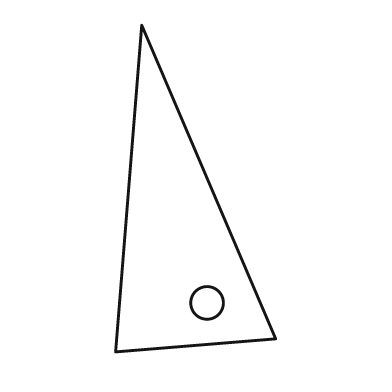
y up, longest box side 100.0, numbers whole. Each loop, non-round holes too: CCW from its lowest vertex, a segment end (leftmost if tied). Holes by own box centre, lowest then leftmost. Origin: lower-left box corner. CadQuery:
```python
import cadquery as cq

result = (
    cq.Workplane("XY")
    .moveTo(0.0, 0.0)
    .lineTo(49.0, 4.0)
    .lineTo(8.0, 100.0)
    .close()
    .moveTo(28.0, 15.0)
    .circle(5.0)
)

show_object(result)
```